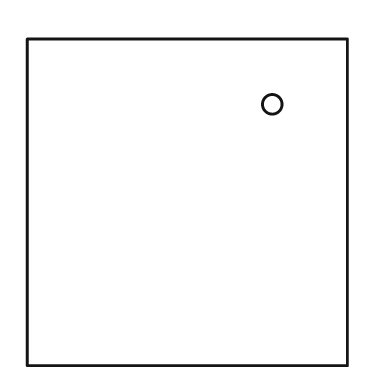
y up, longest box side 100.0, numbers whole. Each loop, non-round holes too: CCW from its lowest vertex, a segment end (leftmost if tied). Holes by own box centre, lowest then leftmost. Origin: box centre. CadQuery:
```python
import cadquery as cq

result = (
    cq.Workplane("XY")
    .moveTo(-49.0, -50.0)
    .lineTo(49.0, -50.0)
    .lineTo(49.0, 50.0)
    .lineTo(-49.0, 50.0)
    .close()
    .moveTo(26.0, 30.0)
    .circle(3.0)
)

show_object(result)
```